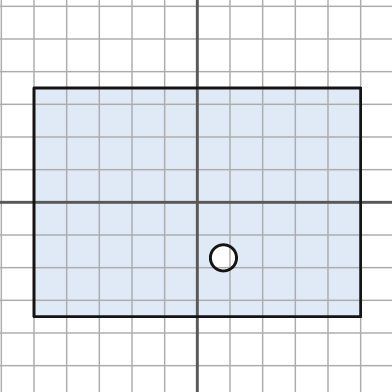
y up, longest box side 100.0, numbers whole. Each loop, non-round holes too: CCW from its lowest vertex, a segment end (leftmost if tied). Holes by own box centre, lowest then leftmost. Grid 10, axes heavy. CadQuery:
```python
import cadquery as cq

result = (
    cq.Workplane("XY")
    .moveTo(-50.0, -35.0)
    .lineTo(50.0, -35.0)
    .lineTo(50.0, 35.0)
    .lineTo(-50.0, 35.0)
    .close()
    .moveTo(8.0, -17.0)
    .circle(4.0)
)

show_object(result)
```